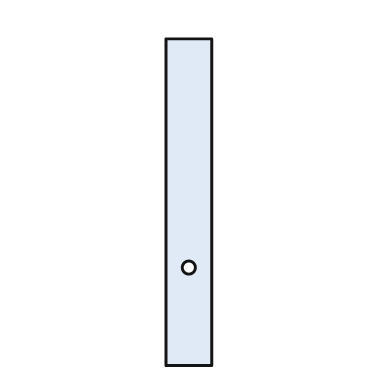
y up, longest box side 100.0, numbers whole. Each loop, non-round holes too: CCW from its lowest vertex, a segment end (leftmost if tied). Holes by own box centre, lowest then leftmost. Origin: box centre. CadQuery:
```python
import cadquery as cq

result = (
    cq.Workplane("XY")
    .moveTo(-7.0, -50.0)
    .lineTo(7.0, -50.0)
    .lineTo(7.0, 50.0)
    .lineTo(-7.0, 50.0)
    .close()
    .moveTo(0.0, -20.0)
    .circle(2.0)
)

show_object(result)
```